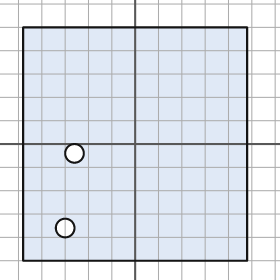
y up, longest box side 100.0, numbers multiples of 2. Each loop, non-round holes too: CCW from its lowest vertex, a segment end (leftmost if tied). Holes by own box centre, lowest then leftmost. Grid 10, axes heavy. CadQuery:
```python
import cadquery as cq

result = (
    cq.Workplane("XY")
    .moveTo(-48.0, -50.0)
    .lineTo(48.0, -50.0)
    .lineTo(48.0, 50.0)
    .lineTo(-48.0, 50.0)
    .close()
    .moveTo(-30.0, -36.0)
    .circle(4.0)
    .moveTo(-26.0, -4.0)
    .circle(4.0)
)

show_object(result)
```